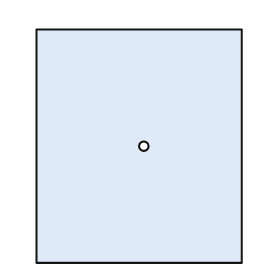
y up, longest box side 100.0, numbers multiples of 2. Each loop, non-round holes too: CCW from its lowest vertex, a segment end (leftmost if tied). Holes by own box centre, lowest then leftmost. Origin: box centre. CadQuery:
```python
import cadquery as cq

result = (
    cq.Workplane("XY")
    .moveTo(-44.0, -50.0)
    .lineTo(44.0, -50.0)
    .lineTo(44.0, 50.0)
    .lineTo(-44.0, 50.0)
    .close()
    .moveTo(2.0, 0.0)
    .circle(2.0)
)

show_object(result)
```